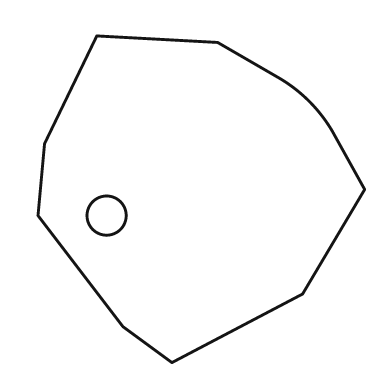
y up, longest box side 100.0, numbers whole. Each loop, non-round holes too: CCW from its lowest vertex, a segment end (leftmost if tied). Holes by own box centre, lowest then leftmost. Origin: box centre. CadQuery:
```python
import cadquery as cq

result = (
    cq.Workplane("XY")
    .moveTo(-9.0, -50.0)
    .lineTo(31.0, -29.0)
    .lineTo(50.0, 3.0)
    .lineTo(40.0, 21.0)
    .threePointArc((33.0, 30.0), (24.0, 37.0))
    .lineTo(5.0, 48.0)
    .lineTo(-32.0, 50.0)
    .lineTo(-48.0, 17.0)
    .lineTo(-50.0, -5.0)
    .lineTo(-24.0, -39.0)
    .close()
    .moveTo(-29.0, -5.0)
    .circle(6.0)
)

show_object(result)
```